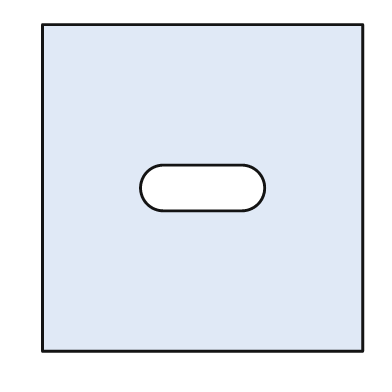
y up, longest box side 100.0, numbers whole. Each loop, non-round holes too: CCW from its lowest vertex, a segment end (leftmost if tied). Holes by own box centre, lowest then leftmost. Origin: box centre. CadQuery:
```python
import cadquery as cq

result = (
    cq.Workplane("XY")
    .moveTo(-49.0, -50.0)
    .lineTo(49.0, -50.0)
    .lineTo(49.0, 50.0)
    .lineTo(-49.0, 50.0)
    .close()
    .moveTo(-12.0, -7.0)
    .lineTo(12.0, -7.0)
    .threePointArc((19.0, 0.0), (12.0, 7.0))
    .lineTo(-12.0, 7.0)
    .threePointArc((-19.0, 0.0), (-12.0, -7.0))
    .close()
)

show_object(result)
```